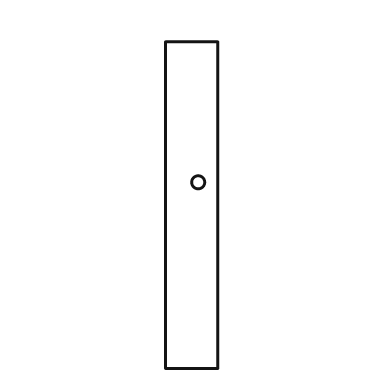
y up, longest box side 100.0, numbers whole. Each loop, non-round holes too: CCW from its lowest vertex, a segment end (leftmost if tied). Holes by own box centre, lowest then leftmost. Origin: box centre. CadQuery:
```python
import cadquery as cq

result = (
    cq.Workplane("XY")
    .moveTo(-8.0, -50.0)
    .lineTo(8.0, -50.0)
    .lineTo(8.0, 50.0)
    .lineTo(-8.0, 50.0)
    .close()
    .moveTo(2.0, 7.0)
    .circle(2.0)
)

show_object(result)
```